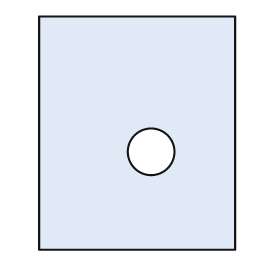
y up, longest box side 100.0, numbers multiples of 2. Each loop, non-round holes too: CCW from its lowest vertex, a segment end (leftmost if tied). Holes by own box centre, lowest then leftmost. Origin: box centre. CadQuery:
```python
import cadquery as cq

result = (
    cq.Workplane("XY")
    .moveTo(-42.0, -50.0)
    .lineTo(42.0, -50.0)
    .lineTo(42.0, 50.0)
    .lineTo(-42.0, 50.0)
    .close()
    .moveTo(6.0, -8.0)
    .circle(10.0)
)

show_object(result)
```